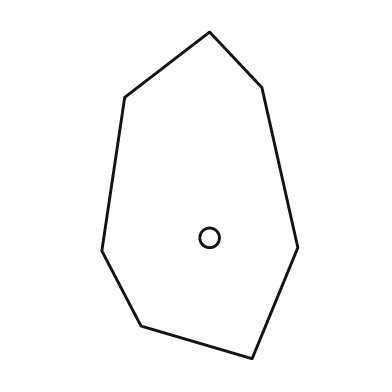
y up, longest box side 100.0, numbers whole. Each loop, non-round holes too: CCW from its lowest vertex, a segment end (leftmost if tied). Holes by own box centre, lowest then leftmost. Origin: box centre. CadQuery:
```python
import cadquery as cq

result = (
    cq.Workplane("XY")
    .moveTo(16.0, -50.0)
    .lineTo(30.0, -16.0)
    .lineTo(19.0, 33.0)
    .lineTo(3.0, 50.0)
    .lineTo(-23.0, 30.0)
    .lineTo(-30.0, -17.0)
    .lineTo(-18.0, -40.0)
    .close()
    .moveTo(3.0, -13.0)
    .circle(3.0)
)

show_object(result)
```